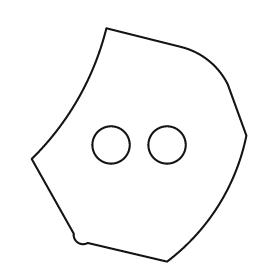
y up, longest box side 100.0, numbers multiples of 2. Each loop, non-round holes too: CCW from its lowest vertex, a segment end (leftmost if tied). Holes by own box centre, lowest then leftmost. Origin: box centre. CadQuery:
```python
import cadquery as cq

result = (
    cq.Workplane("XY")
    .moveTo(12.0, -50.0)
    .threePointArc((34.0, -26.0), (46.0, 4.0))
    .lineTo(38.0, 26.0)
    .threePointArc((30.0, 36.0), (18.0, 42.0))
    .lineTo(-14.0, 50.0)
    .threePointArc((-26.0, 20.0), (-46.0, -6.0))
    .lineTo(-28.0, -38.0)
    .threePointArc((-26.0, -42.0), (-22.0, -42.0))
    .close()
    .moveTo(-12.0, 0.0)
    .circle(8.0)
    .moveTo(12.0, 0.0)
    .circle(8.0)
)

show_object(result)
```